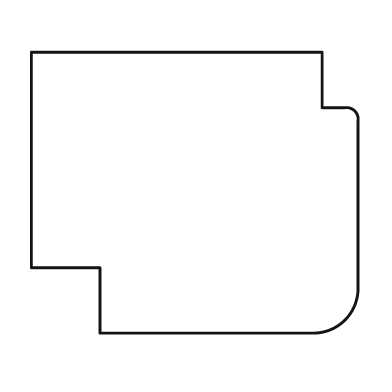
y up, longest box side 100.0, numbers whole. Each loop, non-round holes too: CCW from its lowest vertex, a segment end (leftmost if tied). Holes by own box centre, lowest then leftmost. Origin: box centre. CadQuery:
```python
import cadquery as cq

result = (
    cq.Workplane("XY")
    .moveTo(-29.0, -43.0)
    .lineTo(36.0, -43.0)
    .threePointArc((46.0, -39.0), (50.0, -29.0))
    .lineTo(50.0, 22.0)
    .threePointArc((49.0, 25.0), (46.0, 26.0))
    .lineTo(39.0, 26.0)
    .lineTo(39.0, 43.0)
    .lineTo(-50.0, 43.0)
    .lineTo(-50.0, -23.0)
    .lineTo(-29.0, -23.0)
    .close()
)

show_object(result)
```